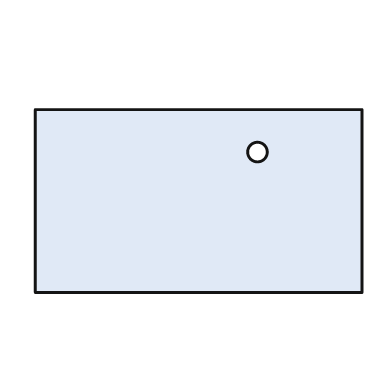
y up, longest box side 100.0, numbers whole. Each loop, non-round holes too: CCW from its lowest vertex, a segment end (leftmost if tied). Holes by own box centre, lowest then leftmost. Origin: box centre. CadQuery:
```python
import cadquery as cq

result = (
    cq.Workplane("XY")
    .moveTo(-50.0, -28.0)
    .lineTo(50.0, -28.0)
    .lineTo(50.0, 28.0)
    .lineTo(-50.0, 28.0)
    .close()
    .moveTo(18.0, 15.0)
    .circle(3.0)
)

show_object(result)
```